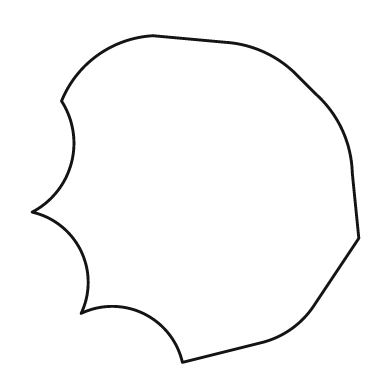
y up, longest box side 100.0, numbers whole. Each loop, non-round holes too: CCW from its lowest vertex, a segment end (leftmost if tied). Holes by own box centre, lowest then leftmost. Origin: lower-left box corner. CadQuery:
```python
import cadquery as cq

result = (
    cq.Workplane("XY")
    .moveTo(46.0, 0.0)
    .lineTo(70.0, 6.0)
    .threePointArc((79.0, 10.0), (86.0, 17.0))
    .lineTo(100.0, 38.0)
    .lineTo(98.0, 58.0)
    .threePointArc((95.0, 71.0), (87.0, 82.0))
    .lineTo(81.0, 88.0)
    .threePointArc((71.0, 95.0), (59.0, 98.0))
    .lineTo(37.0, 100.0)
    .threePointArc((20.0, 94.0), (9.0, 80.0))
    .threePointArc((12.0, 61.0), (0.0, 46.0))
    .threePointArc((15.0, 34.0), (15.0, 15.0))
    .threePointArc((34.0, 15.0), (46.0, 0.0))
    .close()
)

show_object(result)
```